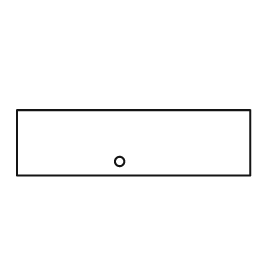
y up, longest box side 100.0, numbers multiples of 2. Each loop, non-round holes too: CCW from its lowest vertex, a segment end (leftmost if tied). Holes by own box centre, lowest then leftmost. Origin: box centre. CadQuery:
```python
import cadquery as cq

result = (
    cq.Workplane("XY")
    .moveTo(-50.0, -14.0)
    .lineTo(50.0, -14.0)
    .lineTo(50.0, 14.0)
    .lineTo(-50.0, 14.0)
    .close()
    .moveTo(-6.0, -8.0)
    .circle(2.0)
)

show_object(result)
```